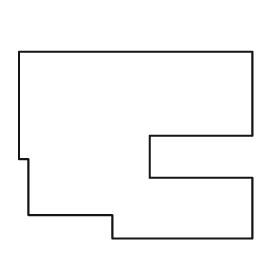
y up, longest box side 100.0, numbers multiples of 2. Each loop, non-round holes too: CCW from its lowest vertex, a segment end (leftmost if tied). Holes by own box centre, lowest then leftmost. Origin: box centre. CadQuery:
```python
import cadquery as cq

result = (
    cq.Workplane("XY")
    .moveTo(-10.0, -40.0)
    .lineTo(50.0, -40.0)
    .lineTo(50.0, -14.0)
    .lineTo(6.0, -14.0)
    .lineTo(6.0, 4.0)
    .lineTo(50.0, 4.0)
    .lineTo(50.0, 40.0)
    .lineTo(-50.0, 40.0)
    .lineTo(-50.0, -6.0)
    .lineTo(-46.0, -6.0)
    .lineTo(-46.0, -30.0)
    .lineTo(-10.0, -30.0)
    .close()
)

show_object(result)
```